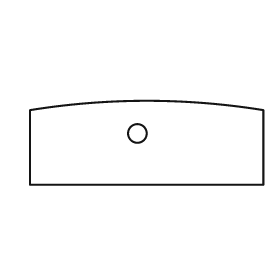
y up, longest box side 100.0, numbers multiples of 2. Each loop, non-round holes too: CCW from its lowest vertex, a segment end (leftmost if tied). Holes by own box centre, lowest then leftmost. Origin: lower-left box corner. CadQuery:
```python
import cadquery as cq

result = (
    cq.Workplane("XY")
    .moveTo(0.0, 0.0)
    .lineTo(100.0, 0.0)
    .lineTo(100.0, 32.0)
    .threePointArc((50.0, 36.0), (0.0, 32.0))
    .close()
    .moveTo(46.0, 22.0)
    .circle(4.0)
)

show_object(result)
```